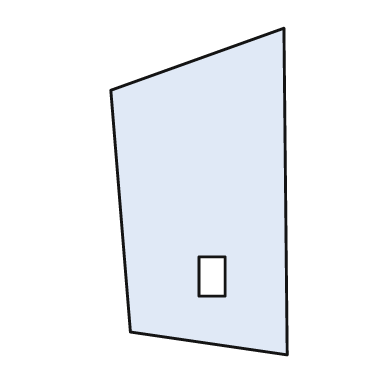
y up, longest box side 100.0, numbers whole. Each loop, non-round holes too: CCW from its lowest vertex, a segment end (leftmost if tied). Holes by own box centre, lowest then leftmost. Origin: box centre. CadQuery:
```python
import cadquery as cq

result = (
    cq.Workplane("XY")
    .moveTo(27.0, -50.0)
    .lineTo(26.0, 50.0)
    .lineTo(-27.0, 31.0)
    .lineTo(-21.0, -43.0)
    .close()
    .moveTo(0.0, -32.0)
    .lineTo(8.0, -32.0)
    .lineTo(8.0, -20.0)
    .lineTo(0.0, -20.0)
    .close()
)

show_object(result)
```